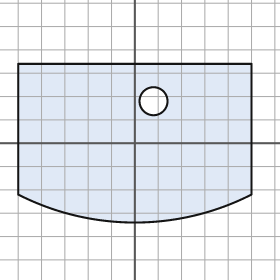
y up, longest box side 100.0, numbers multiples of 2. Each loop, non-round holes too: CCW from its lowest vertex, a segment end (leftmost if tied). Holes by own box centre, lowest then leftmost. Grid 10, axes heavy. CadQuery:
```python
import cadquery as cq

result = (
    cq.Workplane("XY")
    .moveTo(-50.0, -22.0)
    .threePointArc((0.0, -34.0), (50.0, -22.0))
    .lineTo(50.0, 34.0)
    .lineTo(-50.0, 34.0)
    .close()
    .moveTo(8.0, 18.0)
    .circle(6.0)
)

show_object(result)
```